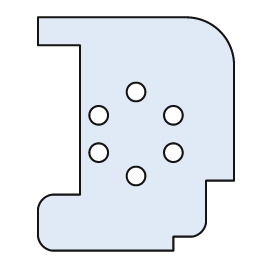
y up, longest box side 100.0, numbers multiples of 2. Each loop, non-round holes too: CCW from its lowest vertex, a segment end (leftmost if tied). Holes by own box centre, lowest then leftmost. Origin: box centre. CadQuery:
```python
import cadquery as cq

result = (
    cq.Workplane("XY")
    .moveTo(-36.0, -50.0)
    .lineTo(16.0, -50.0)
    .lineTo(16.0, -44.0)
    .lineTo(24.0, -44.0)
    .threePointArc((28.0, -42.0), (30.0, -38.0))
    .lineTo(30.0, -20.0)
    .lineTo(42.0, -20.0)
    .lineTo(42.0, 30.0)
    .threePointArc((36.0, 44.0), (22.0, 50.0))
    .lineTo(-42.0, 50.0)
    .lineTo(-42.0, 38.0)
    .lineTo(-24.0, 38.0)
    .lineTo(-24.0, -26.0)
    .lineTo(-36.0, -26.0)
    .threePointArc((-40.0, -28.0), (-42.0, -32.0))
    .lineTo(-42.0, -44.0)
    .threePointArc((-40.0, -48.0), (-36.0, -50.0))
    .close()
    .moveTo(0.0, -18.0)
    .circle(4.0)
    .moveTo(-16.0, -8.0)
    .circle(4.0)
    .moveTo(16.0, -8.0)
    .circle(4.0)
    .moveTo(-16.0, 8.0)
    .circle(4.0)
    .moveTo(16.0, 8.0)
    .circle(4.0)
    .moveTo(0.0, 18.0)
    .circle(4.0)
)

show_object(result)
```